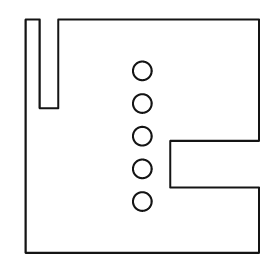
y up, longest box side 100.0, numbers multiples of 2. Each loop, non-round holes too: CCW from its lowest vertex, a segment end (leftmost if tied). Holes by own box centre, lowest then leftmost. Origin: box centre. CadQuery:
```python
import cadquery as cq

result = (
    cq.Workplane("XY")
    .moveTo(-50.0, -50.0)
    .lineTo(50.0, -50.0)
    .lineTo(50.0, -22.0)
    .lineTo(12.0, -22.0)
    .lineTo(12.0, -2.0)
    .lineTo(50.0, -2.0)
    .lineTo(50.0, 50.0)
    .lineTo(-36.0, 50.0)
    .lineTo(-36.0, 12.0)
    .lineTo(-44.0, 12.0)
    .lineTo(-44.0, 50.0)
    .lineTo(-50.0, 50.0)
    .close()
    .moveTo(0.0, -28.0)
    .circle(4.0)
    .moveTo(0.0, -14.0)
    .circle(4.0)
    .moveTo(0.0, 0.0)
    .circle(4.0)
    .moveTo(0.0, 14.0)
    .circle(4.0)
    .moveTo(0.0, 28.0)
    .circle(4.0)
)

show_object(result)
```